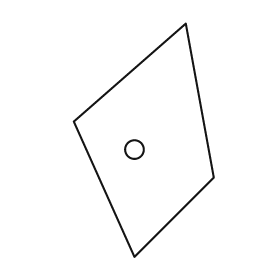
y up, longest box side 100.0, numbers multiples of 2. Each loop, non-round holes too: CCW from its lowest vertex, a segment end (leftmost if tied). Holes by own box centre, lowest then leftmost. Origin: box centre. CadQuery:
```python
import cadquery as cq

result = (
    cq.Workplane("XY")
    .moveTo(-4.0, -50.0)
    .lineTo(30.0, -16.0)
    .lineTo(18.0, 50.0)
    .lineTo(-30.0, 8.0)
    .close()
    .moveTo(-4.0, -4.0)
    .circle(4.0)
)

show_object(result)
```